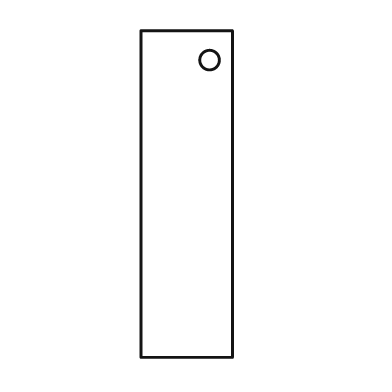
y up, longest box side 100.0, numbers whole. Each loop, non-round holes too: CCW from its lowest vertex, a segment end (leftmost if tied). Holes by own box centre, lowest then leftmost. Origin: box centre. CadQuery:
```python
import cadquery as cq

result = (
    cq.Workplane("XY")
    .moveTo(-14.0, -50.0)
    .lineTo(14.0, -50.0)
    .lineTo(14.0, 50.0)
    .lineTo(-14.0, 50.0)
    .close()
    .moveTo(7.0, 41.0)
    .circle(3.0)
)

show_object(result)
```